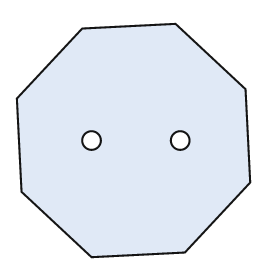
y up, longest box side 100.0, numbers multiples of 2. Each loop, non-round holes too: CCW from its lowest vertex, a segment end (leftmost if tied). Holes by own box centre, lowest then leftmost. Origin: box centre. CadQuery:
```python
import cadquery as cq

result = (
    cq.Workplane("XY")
    .moveTo(-18.0, -50.0)
    .lineTo(22.0, -48.0)
    .lineTo(50.0, -18.0)
    .lineTo(48.0, 22.0)
    .lineTo(18.0, 50.0)
    .lineTo(-22.0, 48.0)
    .lineTo(-50.0, 18.0)
    .lineTo(-48.0, -22.0)
    .close()
    .moveTo(-18.0, 0.0)
    .circle(4.0)
    .moveTo(20.0, 0.0)
    .circle(4.0)
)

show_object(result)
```